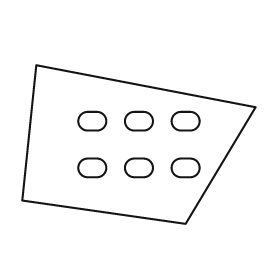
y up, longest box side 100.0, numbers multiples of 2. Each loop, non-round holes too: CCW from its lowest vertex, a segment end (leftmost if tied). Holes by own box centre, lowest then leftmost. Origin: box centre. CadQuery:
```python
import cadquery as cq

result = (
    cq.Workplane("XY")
    .moveTo(20.0, -34.0)
    .lineTo(50.0, 16.0)
    .lineTo(-44.0, 34.0)
    .lineTo(-50.0, -24.0)
    .close()
    .moveTo(-22.0, -14.0)
    .lineTo(-18.0, -14.0)
    .threePointArc((-14.0, -10.0), (-18.0, -6.0))
    .lineTo(-22.0, -6.0)
    .threePointArc((-26.0, -10.0), (-22.0, -14.0))
    .close()
    .moveTo(-2.0, -14.0)
    .lineTo(2.0, -14.0)
    .threePointArc((6.0, -10.0), (2.0, -6.0))
    .lineTo(-2.0, -6.0)
    .threePointArc((-6.0, -10.0), (-2.0, -14.0))
    .close()
    .moveTo(18.0, -14.0)
    .lineTo(22.0, -14.0)
    .threePointArc((26.0, -10.0), (22.0, -6.0))
    .lineTo(18.0, -6.0)
    .threePointArc((14.0, -10.0), (18.0, -14.0))
    .close()
    .moveTo(-22.0, 6.0)
    .lineTo(-18.0, 6.0)
    .threePointArc((-14.0, 10.0), (-18.0, 14.0))
    .lineTo(-22.0, 14.0)
    .threePointArc((-26.0, 10.0), (-22.0, 6.0))
    .close()
    .moveTo(-2.0, 6.0)
    .lineTo(2.0, 6.0)
    .threePointArc((6.0, 10.0), (2.0, 14.0))
    .lineTo(-2.0, 14.0)
    .threePointArc((-6.0, 10.0), (-2.0, 6.0))
    .close()
    .moveTo(18.0, 6.0)
    .lineTo(22.0, 6.0)
    .threePointArc((26.0, 10.0), (22.0, 14.0))
    .lineTo(18.0, 14.0)
    .threePointArc((14.0, 10.0), (18.0, 6.0))
    .close()
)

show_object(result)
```